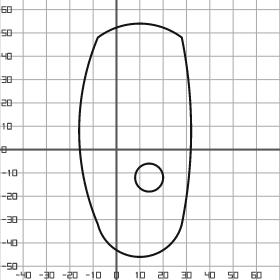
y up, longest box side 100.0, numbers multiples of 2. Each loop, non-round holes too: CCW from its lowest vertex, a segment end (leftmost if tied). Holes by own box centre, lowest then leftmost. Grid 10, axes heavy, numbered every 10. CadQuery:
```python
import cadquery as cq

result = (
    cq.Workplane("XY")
    .moveTo(-8.0, -32.0)
    .threePointArc((10.0, -46.0), (28.0, -32.0))
    .threePointArc((32.0, 8.0), (28.0, 48.0))
    .threePointArc((10.0, 54.0), (-8.0, 48.0))
    .threePointArc((-16.0, 8.0), (-8.0, -32.0))
    .close()
    .moveTo(14.0, -12.0)
    .circle(6.0)
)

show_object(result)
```